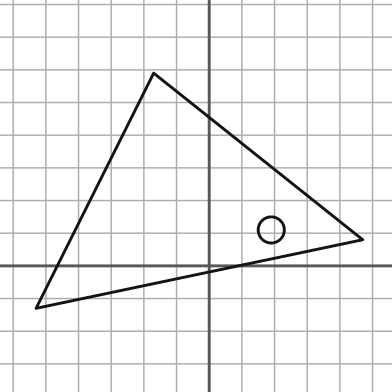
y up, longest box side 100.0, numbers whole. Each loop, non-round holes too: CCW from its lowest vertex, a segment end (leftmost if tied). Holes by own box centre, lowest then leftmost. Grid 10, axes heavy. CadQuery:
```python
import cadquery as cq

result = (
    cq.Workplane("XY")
    .moveTo(-53.0, -13.0)
    .lineTo(47.0, 8.0)
    .lineTo(-17.0, 59.0)
    .close()
    .moveTo(19.0, 11.0)
    .circle(4.0)
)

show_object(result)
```